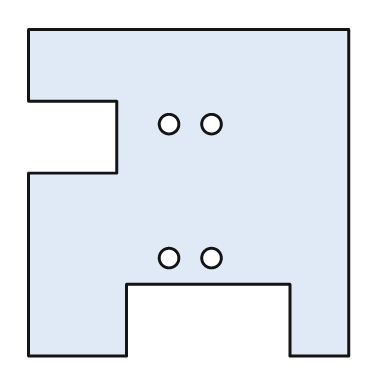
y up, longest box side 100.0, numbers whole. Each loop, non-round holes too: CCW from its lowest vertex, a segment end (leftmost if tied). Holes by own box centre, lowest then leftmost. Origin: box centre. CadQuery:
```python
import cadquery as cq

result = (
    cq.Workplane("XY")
    .moveTo(-49.0, -50.0)
    .lineTo(-19.0, -50.0)
    .lineTo(-19.0, -28.0)
    .lineTo(31.0, -28.0)
    .lineTo(31.0, -50.0)
    .lineTo(49.0, -50.0)
    .lineTo(49.0, 50.0)
    .lineTo(-49.0, 50.0)
    .lineTo(-49.0, 28.0)
    .lineTo(-22.0, 28.0)
    .lineTo(-22.0, 6.0)
    .lineTo(-49.0, 6.0)
    .close()
    .moveTo(-6.0, -20.0)
    .circle(3.0)
    .moveTo(7.0, -20.0)
    .circle(3.0)
    .moveTo(-6.0, 21.0)
    .circle(3.0)
    .moveTo(7.0, 21.0)
    .circle(3.0)
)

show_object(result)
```